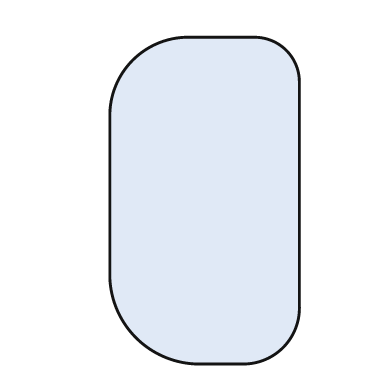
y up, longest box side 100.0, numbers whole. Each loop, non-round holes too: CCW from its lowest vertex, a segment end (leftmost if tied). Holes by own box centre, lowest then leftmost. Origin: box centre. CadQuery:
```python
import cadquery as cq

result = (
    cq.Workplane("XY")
    .moveTo(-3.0, -50.0)
    .lineTo(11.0, -50.0)
    .threePointArc((24.0, -45.0), (29.0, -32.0))
    .lineTo(29.0, 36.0)
    .threePointArc((25.0, 46.0), (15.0, 50.0))
    .lineTo(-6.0, 50.0)
    .threePointArc((-22.0, 43.0), (-29.0, 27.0))
    .lineTo(-29.0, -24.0)
    .threePointArc((-21.0, -42.0), (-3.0, -50.0))
    .close()
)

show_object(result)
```